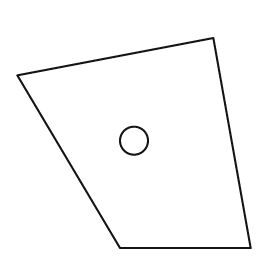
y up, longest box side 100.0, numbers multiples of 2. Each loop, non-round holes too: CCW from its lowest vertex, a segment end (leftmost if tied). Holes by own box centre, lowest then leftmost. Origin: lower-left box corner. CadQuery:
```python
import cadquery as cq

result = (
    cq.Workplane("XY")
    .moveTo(44.0, 0.0)
    .lineTo(100.0, 0.0)
    .lineTo(84.0, 90.0)
    .lineTo(0.0, 74.0)
    .close()
    .moveTo(50.0, 46.0)
    .circle(6.0)
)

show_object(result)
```